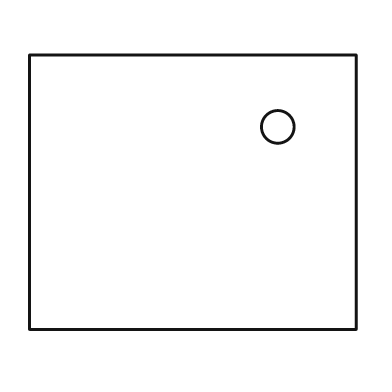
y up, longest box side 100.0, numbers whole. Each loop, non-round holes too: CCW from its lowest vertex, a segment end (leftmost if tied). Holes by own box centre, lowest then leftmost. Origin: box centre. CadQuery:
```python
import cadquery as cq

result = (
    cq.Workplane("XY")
    .moveTo(-50.0, -42.0)
    .lineTo(50.0, -42.0)
    .lineTo(50.0, 42.0)
    .lineTo(-50.0, 42.0)
    .close()
    .moveTo(26.0, 20.0)
    .circle(5.0)
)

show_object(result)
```